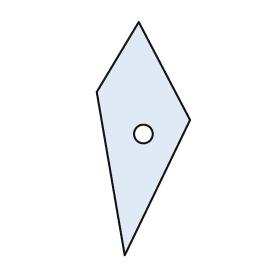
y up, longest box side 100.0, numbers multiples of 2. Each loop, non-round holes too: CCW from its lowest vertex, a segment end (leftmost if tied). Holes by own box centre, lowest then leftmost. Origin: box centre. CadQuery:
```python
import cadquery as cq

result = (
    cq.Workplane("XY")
    .moveTo(-8.0, -50.0)
    .lineTo(20.0, 8.0)
    .lineTo(-2.0, 50.0)
    .lineTo(-20.0, 20.0)
    .close()
    .moveTo(0.0, 2.0)
    .circle(4.0)
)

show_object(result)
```